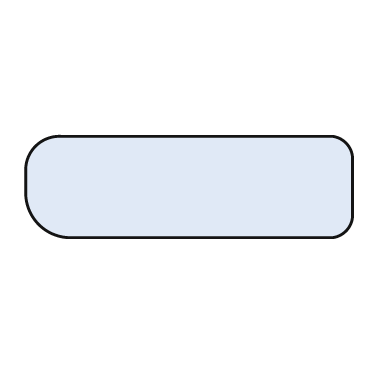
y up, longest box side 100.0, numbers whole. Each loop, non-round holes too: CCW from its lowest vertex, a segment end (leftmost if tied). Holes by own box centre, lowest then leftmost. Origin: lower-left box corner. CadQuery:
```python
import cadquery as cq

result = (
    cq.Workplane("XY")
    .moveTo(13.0, 0.0)
    .lineTo(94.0, 0.0)
    .threePointArc((98.0, 2.0), (100.0, 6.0))
    .lineTo(100.0, 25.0)
    .threePointArc((98.0, 29.0), (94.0, 31.0))
    .lineTo(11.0, 31.0)
    .threePointArc((3.0, 28.0), (0.0, 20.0))
    .lineTo(0.0, 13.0)
    .threePointArc((4.0, 4.0), (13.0, 0.0))
    .close()
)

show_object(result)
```